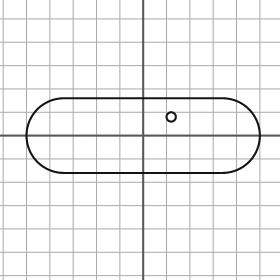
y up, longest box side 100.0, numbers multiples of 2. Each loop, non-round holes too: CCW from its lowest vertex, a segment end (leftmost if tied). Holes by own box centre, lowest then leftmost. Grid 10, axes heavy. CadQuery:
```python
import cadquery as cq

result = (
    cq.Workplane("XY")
    .moveTo(-34.0, -16.0)
    .lineTo(34.0, -16.0)
    .threePointArc((50.0, 0.0), (34.0, 16.0))
    .lineTo(-34.0, 16.0)
    .threePointArc((-50.0, 0.0), (-34.0, -16.0))
    .close()
    .moveTo(12.0, 8.0)
    .circle(2.0)
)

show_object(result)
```